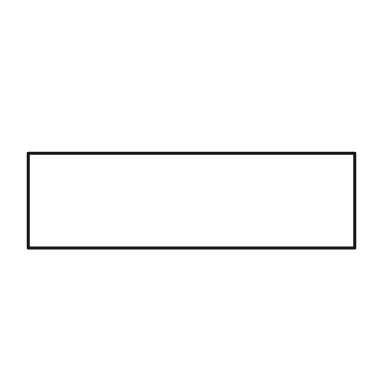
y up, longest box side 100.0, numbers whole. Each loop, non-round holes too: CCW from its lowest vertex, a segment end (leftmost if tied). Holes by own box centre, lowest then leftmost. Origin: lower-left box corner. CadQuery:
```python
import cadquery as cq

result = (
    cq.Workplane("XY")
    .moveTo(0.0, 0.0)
    .lineTo(100.0, 0.0)
    .lineTo(100.0, 29.0)
    .lineTo(0.0, 29.0)
    .close()
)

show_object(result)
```